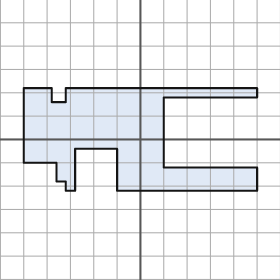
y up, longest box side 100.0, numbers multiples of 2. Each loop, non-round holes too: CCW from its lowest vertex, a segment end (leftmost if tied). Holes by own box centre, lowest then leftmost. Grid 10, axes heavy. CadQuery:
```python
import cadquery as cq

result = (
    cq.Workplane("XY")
    .moveTo(-32.0, -22.0)
    .lineTo(-28.0, -22.0)
    .lineTo(-28.0, -4.0)
    .lineTo(-10.0, -4.0)
    .lineTo(-10.0, -22.0)
    .lineTo(50.0, -22.0)
    .lineTo(50.0, -12.0)
    .lineTo(10.0, -12.0)
    .lineTo(10.0, 18.0)
    .lineTo(50.0, 18.0)
    .lineTo(50.0, 22.0)
    .lineTo(-32.0, 22.0)
    .lineTo(-32.0, 16.0)
    .lineTo(-38.0, 16.0)
    .lineTo(-38.0, 22.0)
    .lineTo(-50.0, 22.0)
    .lineTo(-50.0, -10.0)
    .lineTo(-36.0, -10.0)
    .lineTo(-36.0, -18.0)
    .lineTo(-32.0, -18.0)
    .close()
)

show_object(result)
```